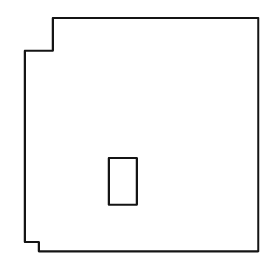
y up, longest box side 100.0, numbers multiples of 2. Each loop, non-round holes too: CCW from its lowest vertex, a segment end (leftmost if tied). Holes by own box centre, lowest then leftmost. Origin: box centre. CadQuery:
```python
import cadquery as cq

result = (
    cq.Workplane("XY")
    .moveTo(-44.0, -50.0)
    .lineTo(50.0, -50.0)
    .lineTo(50.0, 50.0)
    .lineTo(-38.0, 50.0)
    .lineTo(-38.0, 36.0)
    .lineTo(-50.0, 36.0)
    .lineTo(-50.0, -46.0)
    .lineTo(-44.0, -46.0)
    .close()
    .moveTo(-14.0, -30.0)
    .lineTo(-2.0, -30.0)
    .lineTo(-2.0, -10.0)
    .lineTo(-14.0, -10.0)
    .close()
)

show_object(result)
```